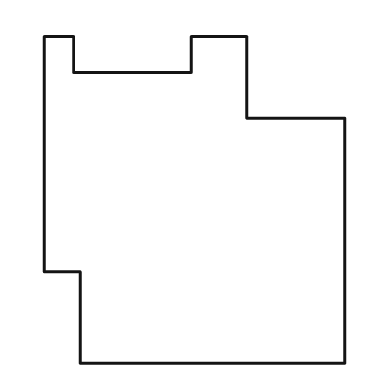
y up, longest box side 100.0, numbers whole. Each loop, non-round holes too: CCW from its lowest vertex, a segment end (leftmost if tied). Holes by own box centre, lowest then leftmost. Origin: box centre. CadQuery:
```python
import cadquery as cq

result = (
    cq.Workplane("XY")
    .moveTo(-35.0, -50.0)
    .lineTo(46.0, -50.0)
    .lineTo(46.0, 25.0)
    .lineTo(16.0, 25.0)
    .lineTo(16.0, 50.0)
    .lineTo(-1.0, 50.0)
    .lineTo(-1.0, 39.0)
    .lineTo(-37.0, 39.0)
    .lineTo(-37.0, 50.0)
    .lineTo(-46.0, 50.0)
    .lineTo(-46.0, -22.0)
    .lineTo(-35.0, -22.0)
    .close()
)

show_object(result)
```